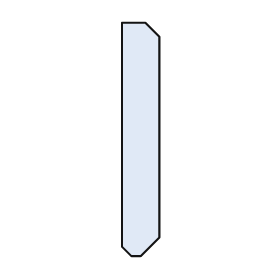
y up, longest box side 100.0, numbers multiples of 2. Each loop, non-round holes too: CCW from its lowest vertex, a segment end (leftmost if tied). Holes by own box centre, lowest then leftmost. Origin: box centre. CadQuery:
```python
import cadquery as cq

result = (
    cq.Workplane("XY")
    .moveTo(-4.0, -50.0)
    .lineTo(0.0, -50.0)
    .lineTo(8.0, -42.0)
    .lineTo(8.0, 44.0)
    .lineTo(2.0, 50.0)
    .lineTo(-8.0, 50.0)
    .lineTo(-8.0, -46.0)
    .close()
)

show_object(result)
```